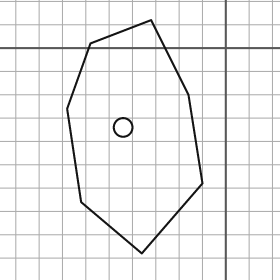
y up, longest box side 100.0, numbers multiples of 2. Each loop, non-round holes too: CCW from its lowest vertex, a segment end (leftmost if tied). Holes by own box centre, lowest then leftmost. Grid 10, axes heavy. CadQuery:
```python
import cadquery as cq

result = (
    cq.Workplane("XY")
    .moveTo(-36.0, -88.0)
    .lineTo(-10.0, -58.0)
    .lineTo(-16.0, -20.0)
    .lineTo(-32.0, 12.0)
    .lineTo(-58.0, 2.0)
    .lineTo(-68.0, -26.0)
    .lineTo(-62.0, -66.0)
    .close()
    .moveTo(-44.0, -34.0)
    .circle(4.0)
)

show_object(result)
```